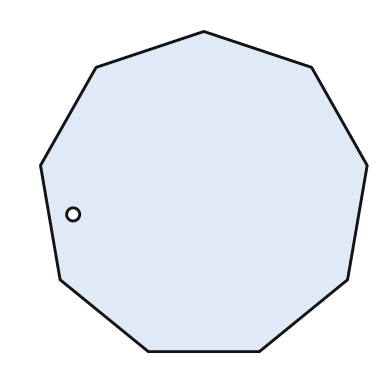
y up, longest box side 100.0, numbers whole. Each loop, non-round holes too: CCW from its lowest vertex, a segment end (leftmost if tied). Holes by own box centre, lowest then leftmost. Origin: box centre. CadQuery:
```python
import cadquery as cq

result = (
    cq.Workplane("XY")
    .moveTo(-17.0, -49.0)
    .lineTo(17.0, -49.0)
    .lineTo(44.0, -27.0)
    .lineTo(50.0, 8.0)
    .lineTo(33.0, 38.0)
    .lineTo(0.0, 49.0)
    .lineTo(-33.0, 38.0)
    .lineTo(-50.0, 8.0)
    .lineTo(-44.0, -27.0)
    .close()
    .moveTo(-40.0, -7.0)
    .circle(2.0)
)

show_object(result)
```